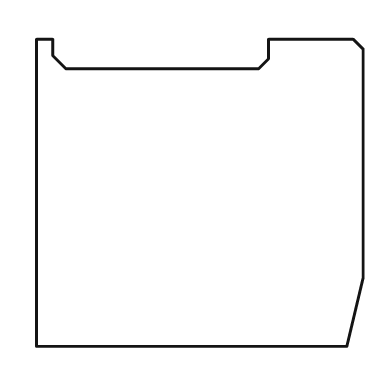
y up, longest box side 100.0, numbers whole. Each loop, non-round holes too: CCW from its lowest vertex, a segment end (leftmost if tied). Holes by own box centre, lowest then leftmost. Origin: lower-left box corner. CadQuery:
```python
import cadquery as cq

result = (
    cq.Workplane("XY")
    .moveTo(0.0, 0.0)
    .lineTo(95.0, 0.0)
    .lineTo(100.0, 21.0)
    .lineTo(100.0, 91.0)
    .lineTo(97.0, 94.0)
    .lineTo(71.0, 94.0)
    .lineTo(71.0, 88.0)
    .lineTo(68.0, 85.0)
    .lineTo(9.0, 85.0)
    .lineTo(5.0, 89.0)
    .lineTo(5.0, 94.0)
    .lineTo(0.0, 94.0)
    .close()
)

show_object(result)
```